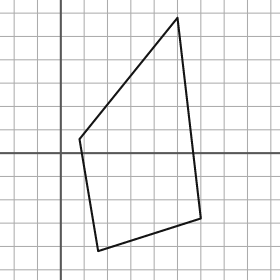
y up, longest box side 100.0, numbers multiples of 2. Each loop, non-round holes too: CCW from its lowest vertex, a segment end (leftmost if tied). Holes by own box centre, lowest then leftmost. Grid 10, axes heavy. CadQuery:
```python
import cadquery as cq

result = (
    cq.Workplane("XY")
    .moveTo(16.0, -42.0)
    .lineTo(60.0, -28.0)
    .lineTo(50.0, 58.0)
    .lineTo(8.0, 6.0)
    .close()
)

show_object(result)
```